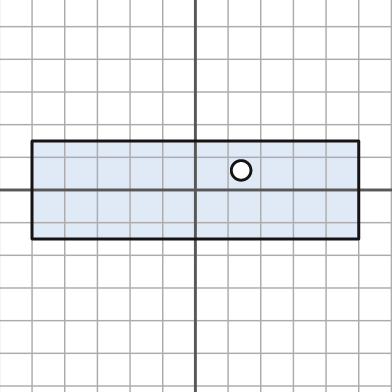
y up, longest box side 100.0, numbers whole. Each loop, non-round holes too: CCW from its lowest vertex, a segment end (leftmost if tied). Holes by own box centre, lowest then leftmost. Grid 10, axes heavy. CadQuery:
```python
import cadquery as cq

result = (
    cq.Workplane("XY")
    .moveTo(-50.0, -15.0)
    .lineTo(50.0, -15.0)
    .lineTo(50.0, 15.0)
    .lineTo(-50.0, 15.0)
    .close()
    .moveTo(14.0, 6.0)
    .circle(3.0)
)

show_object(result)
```